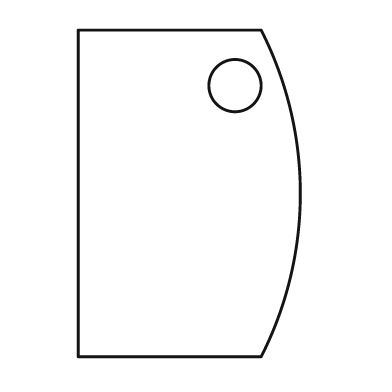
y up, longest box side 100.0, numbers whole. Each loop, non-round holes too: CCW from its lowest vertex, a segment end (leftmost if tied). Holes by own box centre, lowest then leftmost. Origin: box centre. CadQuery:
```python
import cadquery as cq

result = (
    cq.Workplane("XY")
    .moveTo(-34.0, -50.0)
    .lineTo(22.0, -50.0)
    .threePointArc((34.0, 0.0), (22.0, 50.0))
    .lineTo(-34.0, 50.0)
    .close()
    .moveTo(14.0, 33.0)
    .circle(8.0)
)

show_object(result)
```